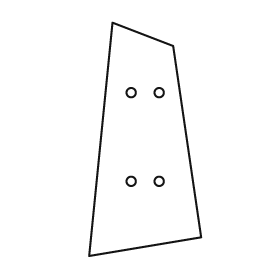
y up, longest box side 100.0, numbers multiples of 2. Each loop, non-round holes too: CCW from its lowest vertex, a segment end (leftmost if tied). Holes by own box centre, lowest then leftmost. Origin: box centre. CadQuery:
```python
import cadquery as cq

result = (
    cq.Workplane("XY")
    .moveTo(-24.0, -50.0)
    .lineTo(24.0, -42.0)
    .lineTo(12.0, 40.0)
    .lineTo(-14.0, 50.0)
    .close()
    .moveTo(-6.0, -18.0)
    .circle(2.0)
    .moveTo(6.0, -18.0)
    .circle(2.0)
    .moveTo(-6.0, 20.0)
    .circle(2.0)
    .moveTo(6.0, 20.0)
    .circle(2.0)
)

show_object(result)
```